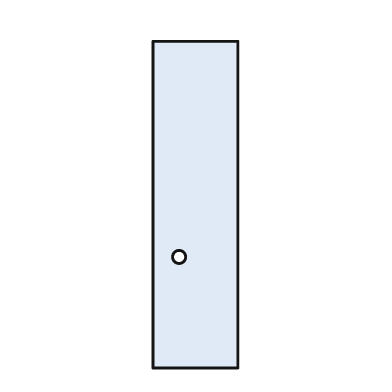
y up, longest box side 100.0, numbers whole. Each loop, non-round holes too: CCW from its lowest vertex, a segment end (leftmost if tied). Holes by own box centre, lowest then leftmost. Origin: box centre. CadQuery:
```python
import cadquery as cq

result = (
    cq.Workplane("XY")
    .moveTo(-13.0, -50.0)
    .lineTo(13.0, -50.0)
    .lineTo(13.0, 50.0)
    .lineTo(-13.0, 50.0)
    .close()
    .moveTo(-5.0, -16.0)
    .circle(2.0)
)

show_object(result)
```